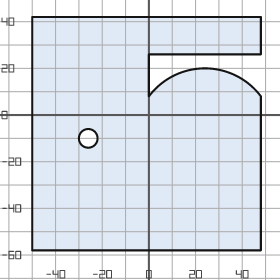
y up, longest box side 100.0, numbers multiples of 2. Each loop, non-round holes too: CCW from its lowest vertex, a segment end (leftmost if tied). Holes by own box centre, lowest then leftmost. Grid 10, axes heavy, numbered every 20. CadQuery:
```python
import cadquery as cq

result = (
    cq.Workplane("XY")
    .moveTo(-50.0, -58.0)
    .lineTo(48.0, -58.0)
    .lineTo(48.0, 8.0)
    .threePointArc((24.0, 20.0), (0.0, 8.0))
    .lineTo(0.0, 26.0)
    .lineTo(48.0, 26.0)
    .lineTo(48.0, 42.0)
    .lineTo(-50.0, 42.0)
    .close()
    .moveTo(-26.0, -10.0)
    .circle(4.0)
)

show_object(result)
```